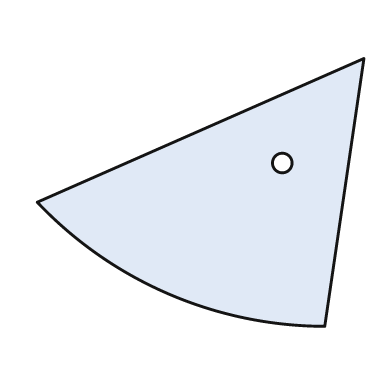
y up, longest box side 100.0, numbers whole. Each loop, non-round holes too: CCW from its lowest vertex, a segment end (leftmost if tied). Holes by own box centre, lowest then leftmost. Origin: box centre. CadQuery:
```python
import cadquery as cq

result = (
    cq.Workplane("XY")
    .moveTo(38.0, -41.0)
    .lineTo(50.0, 41.0)
    .lineTo(-50.0, -3.0)
    .threePointArc((-10.0, -31.0), (38.0, -41.0))
    .close()
    .moveTo(25.0, 9.0)
    .circle(3.0)
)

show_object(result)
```